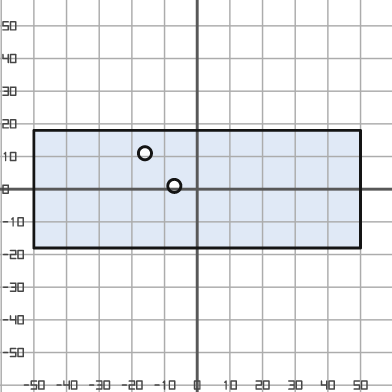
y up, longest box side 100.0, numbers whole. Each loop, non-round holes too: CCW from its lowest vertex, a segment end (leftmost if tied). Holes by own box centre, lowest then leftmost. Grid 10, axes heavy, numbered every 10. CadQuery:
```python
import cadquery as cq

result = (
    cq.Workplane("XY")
    .moveTo(-50.0, -18.0)
    .lineTo(50.0, -18.0)
    .lineTo(50.0, 18.0)
    .lineTo(-50.0, 18.0)
    .close()
    .moveTo(-7.0, 1.0)
    .circle(2.0)
    .moveTo(-16.0, 11.0)
    .circle(2.0)
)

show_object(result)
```